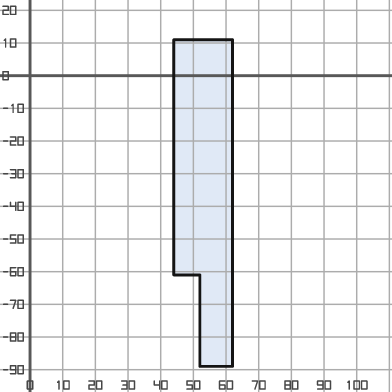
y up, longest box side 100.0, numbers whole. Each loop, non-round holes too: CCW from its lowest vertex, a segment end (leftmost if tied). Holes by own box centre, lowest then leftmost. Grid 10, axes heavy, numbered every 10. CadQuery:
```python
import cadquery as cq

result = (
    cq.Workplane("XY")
    .moveTo(52.0, -89.0)
    .lineTo(62.0, -89.0)
    .lineTo(62.0, 11.0)
    .lineTo(44.0, 11.0)
    .lineTo(44.0, -61.0)
    .lineTo(52.0, -61.0)
    .close()
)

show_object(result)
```